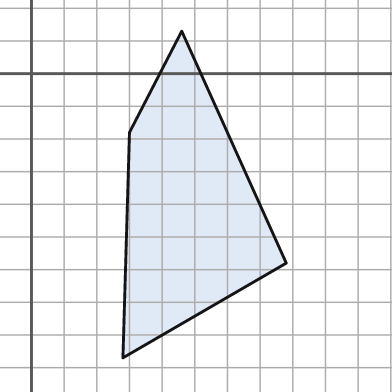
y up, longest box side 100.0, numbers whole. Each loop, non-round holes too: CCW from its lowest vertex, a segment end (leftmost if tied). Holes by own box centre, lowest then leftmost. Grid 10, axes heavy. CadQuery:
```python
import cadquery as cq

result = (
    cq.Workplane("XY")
    .moveTo(28.0, -87.0)
    .lineTo(78.0, -58.0)
    .lineTo(46.0, 13.0)
    .lineTo(30.0, -18.0)
    .close()
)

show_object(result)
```